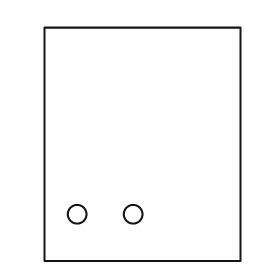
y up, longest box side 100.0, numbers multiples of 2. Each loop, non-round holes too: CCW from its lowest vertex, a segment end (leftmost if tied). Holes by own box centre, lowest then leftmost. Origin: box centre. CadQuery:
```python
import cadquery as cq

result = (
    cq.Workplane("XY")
    .moveTo(-42.0, -50.0)
    .lineTo(42.0, -50.0)
    .lineTo(42.0, 50.0)
    .lineTo(-42.0, 50.0)
    .close()
    .moveTo(-28.0, -30.0)
    .circle(4.0)
    .moveTo(-4.0, -30.0)
    .circle(4.0)
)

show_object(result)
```